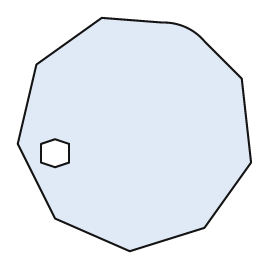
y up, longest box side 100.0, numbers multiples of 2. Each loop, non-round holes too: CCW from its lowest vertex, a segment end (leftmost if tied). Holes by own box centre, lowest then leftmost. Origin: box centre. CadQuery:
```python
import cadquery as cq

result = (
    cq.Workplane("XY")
    .moveTo(-2.0, -50.0)
    .lineTo(30.0, -40.0)
    .lineTo(50.0, -12.0)
    .lineTo(46.0, 24.0)
    .lineTo(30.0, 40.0)
    .threePointArc((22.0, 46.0), (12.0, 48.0))
    .lineTo(-14.0, 50.0)
    .lineTo(-42.0, 30.0)
    .lineTo(-50.0, -4.0)
    .lineTo(-34.0, -36.0)
    .close()
    .moveTo(-34.0, -14.0)
    .lineTo(-28.0, -12.0)
    .lineTo(-28.0, -4.0)
    .lineTo(-34.0, -2.0)
    .lineTo(-40.0, -4.0)
    .lineTo(-40.0, -12.0)
    .close()
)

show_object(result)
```